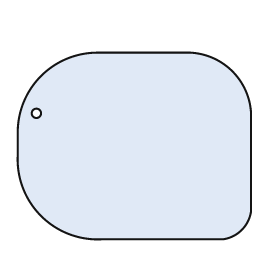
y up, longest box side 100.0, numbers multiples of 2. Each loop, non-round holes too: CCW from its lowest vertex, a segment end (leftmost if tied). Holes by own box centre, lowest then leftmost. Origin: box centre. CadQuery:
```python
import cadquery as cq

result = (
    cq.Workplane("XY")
    .moveTo(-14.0, -40.0)
    .lineTo(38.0, -40.0)
    .threePointArc((46.0, -36.0), (50.0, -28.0))
    .lineTo(50.0, 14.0)
    .threePointArc((42.0, 32.0), (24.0, 40.0))
    .lineTo(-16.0, 40.0)
    .threePointArc((-40.0, 30.0), (-50.0, 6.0))
    .lineTo(-50.0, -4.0)
    .threePointArc((-40.0, -30.0), (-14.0, -40.0))
    .close()
    .moveTo(-42.0, 14.0)
    .circle(2.0)
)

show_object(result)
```